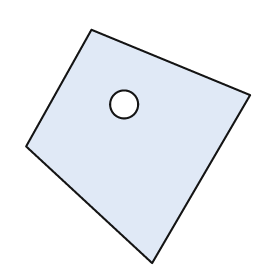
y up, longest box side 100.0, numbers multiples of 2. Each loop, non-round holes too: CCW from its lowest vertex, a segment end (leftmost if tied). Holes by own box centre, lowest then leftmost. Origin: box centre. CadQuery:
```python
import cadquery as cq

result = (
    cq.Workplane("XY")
    .moveTo(6.0, -50.0)
    .lineTo(48.0, 22.0)
    .lineTo(-20.0, 50.0)
    .lineTo(-48.0, 0.0)
    .close()
    .moveTo(-6.0, 18.0)
    .circle(6.0)
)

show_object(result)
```